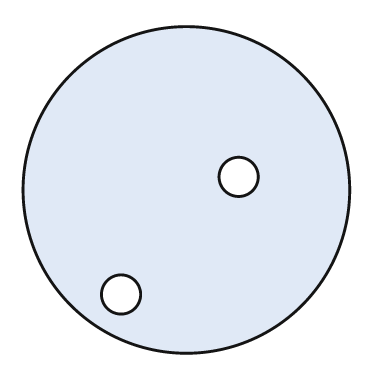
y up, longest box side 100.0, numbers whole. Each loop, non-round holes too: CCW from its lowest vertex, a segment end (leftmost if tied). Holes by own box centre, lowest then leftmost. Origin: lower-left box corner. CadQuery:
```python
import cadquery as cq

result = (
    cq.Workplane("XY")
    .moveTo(50.0, 50.0)
    .circle(50.0)
    .moveTo(30.0, 18.0)
    .circle(6.0)
    .moveTo(66.0, 54.0)
    .circle(6.0)
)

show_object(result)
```